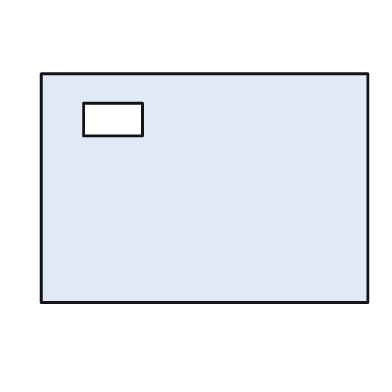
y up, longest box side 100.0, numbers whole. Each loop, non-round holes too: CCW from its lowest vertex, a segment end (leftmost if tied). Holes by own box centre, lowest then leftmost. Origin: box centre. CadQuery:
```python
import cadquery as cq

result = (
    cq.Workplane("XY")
    .moveTo(-50.0, -35.0)
    .lineTo(50.0, -35.0)
    .lineTo(50.0, 35.0)
    .lineTo(-50.0, 35.0)
    .close()
    .moveTo(-37.0, 16.0)
    .lineTo(-19.0, 16.0)
    .lineTo(-19.0, 26.0)
    .lineTo(-37.0, 26.0)
    .close()
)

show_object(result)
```